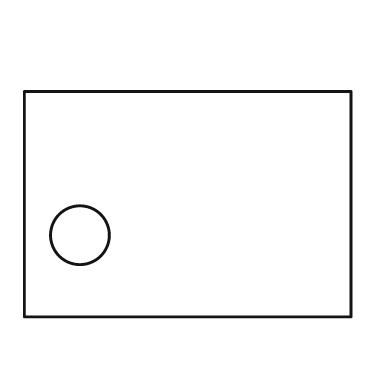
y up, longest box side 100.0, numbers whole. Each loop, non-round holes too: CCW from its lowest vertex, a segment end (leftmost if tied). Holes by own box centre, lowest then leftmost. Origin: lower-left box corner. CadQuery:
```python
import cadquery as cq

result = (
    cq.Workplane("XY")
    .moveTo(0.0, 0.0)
    .lineTo(100.0, 0.0)
    .lineTo(100.0, 69.0)
    .lineTo(0.0, 69.0)
    .close()
    .moveTo(17.0, 25.0)
    .circle(9.0)
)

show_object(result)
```